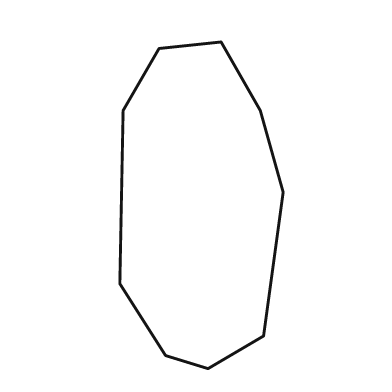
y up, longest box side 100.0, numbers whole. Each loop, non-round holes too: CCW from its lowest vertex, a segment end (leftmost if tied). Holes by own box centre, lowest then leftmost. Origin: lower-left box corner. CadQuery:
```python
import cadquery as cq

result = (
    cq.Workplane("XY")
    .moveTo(27.0, 0.0)
    .lineTo(44.0, 10.0)
    .lineTo(50.0, 54.0)
    .lineTo(43.0, 79.0)
    .lineTo(31.0, 100.0)
    .lineTo(12.0, 98.0)
    .lineTo(1.0, 79.0)
    .lineTo(0.0, 26.0)
    .lineTo(14.0, 4.0)
    .close()
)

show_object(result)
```